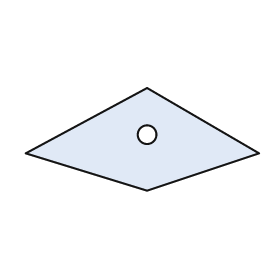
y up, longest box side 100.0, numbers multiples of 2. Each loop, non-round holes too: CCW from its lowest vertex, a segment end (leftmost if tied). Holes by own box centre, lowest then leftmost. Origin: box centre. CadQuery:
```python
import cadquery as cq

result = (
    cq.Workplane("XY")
    .moveTo(2.0, -22.0)
    .lineTo(50.0, -6.0)
    .lineTo(2.0, 22.0)
    .lineTo(-50.0, -6.0)
    .close()
    .moveTo(2.0, 2.0)
    .circle(4.0)
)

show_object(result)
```